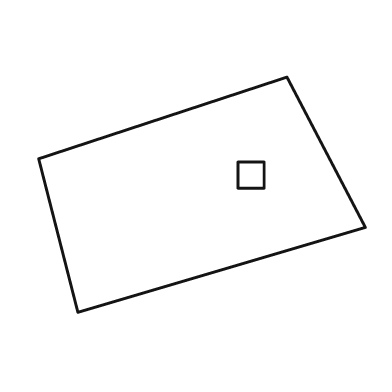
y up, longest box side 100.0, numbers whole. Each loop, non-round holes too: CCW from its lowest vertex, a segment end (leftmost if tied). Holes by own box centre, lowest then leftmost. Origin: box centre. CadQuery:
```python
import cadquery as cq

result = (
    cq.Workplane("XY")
    .moveTo(-38.0, -36.0)
    .lineTo(50.0, -10.0)
    .lineTo(26.0, 36.0)
    .lineTo(-50.0, 11.0)
    .close()
    .moveTo(11.0, 2.0)
    .lineTo(19.0, 2.0)
    .lineTo(19.0, 10.0)
    .lineTo(11.0, 10.0)
    .close()
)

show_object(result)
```